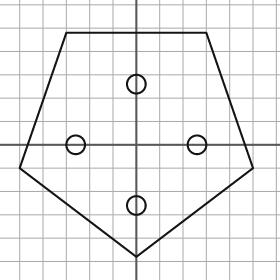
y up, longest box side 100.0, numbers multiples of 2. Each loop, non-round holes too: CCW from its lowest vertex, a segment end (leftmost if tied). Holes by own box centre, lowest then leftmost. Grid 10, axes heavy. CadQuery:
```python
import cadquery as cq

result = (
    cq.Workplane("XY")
    .moveTo(0.0, -48.0)
    .lineTo(50.0, -10.0)
    .lineTo(30.0, 48.0)
    .lineTo(-30.0, 48.0)
    .lineTo(-50.0, -10.0)
    .close()
    .moveTo(0.0, -26.0)
    .circle(4.0)
    .moveTo(-26.0, 0.0)
    .circle(4.0)
    .moveTo(26.0, 0.0)
    .circle(4.0)
    .moveTo(0.0, 26.0)
    .circle(4.0)
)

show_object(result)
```